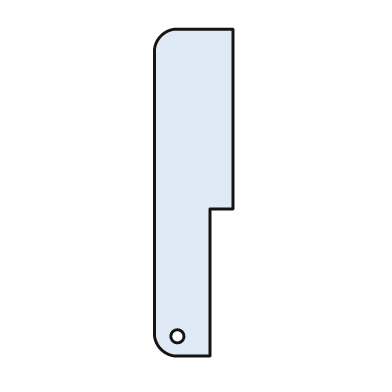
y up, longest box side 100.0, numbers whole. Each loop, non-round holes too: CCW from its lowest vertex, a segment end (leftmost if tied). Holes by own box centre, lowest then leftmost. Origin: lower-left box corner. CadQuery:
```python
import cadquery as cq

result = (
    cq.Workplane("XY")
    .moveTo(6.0, 0.0)
    .lineTo(17.0, 0.0)
    .lineTo(17.0, 45.0)
    .lineTo(24.0, 45.0)
    .lineTo(24.0, 100.0)
    .lineTo(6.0, 100.0)
    .threePointArc((2.0, 98.0), (0.0, 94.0))
    .lineTo(0.0, 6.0)
    .threePointArc((2.0, 2.0), (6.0, 0.0))
    .close()
    .moveTo(7.0, 6.0)
    .circle(2.0)
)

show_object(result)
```